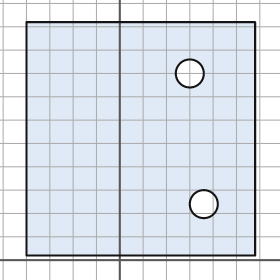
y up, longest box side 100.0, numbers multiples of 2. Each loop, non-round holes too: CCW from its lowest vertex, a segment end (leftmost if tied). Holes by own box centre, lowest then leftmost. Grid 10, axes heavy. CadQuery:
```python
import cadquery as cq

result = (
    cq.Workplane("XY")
    .moveTo(-40.0, 2.0)
    .lineTo(58.0, 2.0)
    .lineTo(58.0, 102.0)
    .lineTo(-40.0, 102.0)
    .close()
    .moveTo(36.0, 24.0)
    .circle(6.0)
    .moveTo(30.0, 80.0)
    .circle(6.0)
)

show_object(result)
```